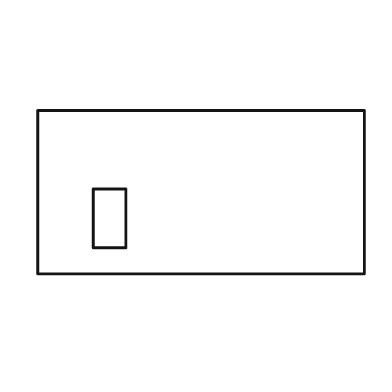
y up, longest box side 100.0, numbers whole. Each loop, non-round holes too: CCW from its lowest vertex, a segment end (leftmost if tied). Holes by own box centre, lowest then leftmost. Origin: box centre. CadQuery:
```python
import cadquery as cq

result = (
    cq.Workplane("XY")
    .moveTo(-50.0, -25.0)
    .lineTo(50.0, -25.0)
    .lineTo(50.0, 25.0)
    .lineTo(-50.0, 25.0)
    .close()
    .moveTo(-33.0, -17.0)
    .lineTo(-23.0, -17.0)
    .lineTo(-23.0, 1.0)
    .lineTo(-33.0, 1.0)
    .close()
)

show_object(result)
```